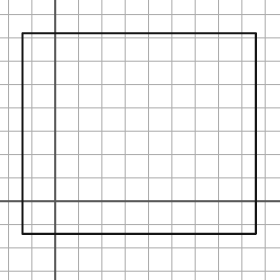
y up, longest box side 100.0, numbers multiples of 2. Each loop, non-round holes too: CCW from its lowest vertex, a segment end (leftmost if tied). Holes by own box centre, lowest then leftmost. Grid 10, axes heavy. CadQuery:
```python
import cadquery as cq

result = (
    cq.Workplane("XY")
    .moveTo(-14.0, -14.0)
    .lineTo(86.0, -14.0)
    .lineTo(86.0, 72.0)
    .lineTo(-14.0, 72.0)
    .close()
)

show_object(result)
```